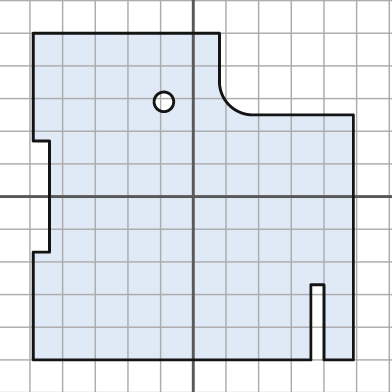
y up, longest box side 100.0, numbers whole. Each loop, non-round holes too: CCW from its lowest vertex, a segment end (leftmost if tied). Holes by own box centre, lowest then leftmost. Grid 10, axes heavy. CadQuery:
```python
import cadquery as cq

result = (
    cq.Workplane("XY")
    .moveTo(-49.0, -50.0)
    .lineTo(36.0, -50.0)
    .lineTo(36.0, -27.0)
    .lineTo(40.0, -27.0)
    .lineTo(40.0, -50.0)
    .lineTo(49.0, -50.0)
    .lineTo(49.0, 25.0)
    .lineTo(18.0, 25.0)
    .threePointArc((11.0, 28.0), (8.0, 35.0))
    .lineTo(8.0, 50.0)
    .lineTo(-49.0, 50.0)
    .lineTo(-49.0, 17.0)
    .lineTo(-44.0, 17.0)
    .lineTo(-44.0, -17.0)
    .lineTo(-49.0, -17.0)
    .close()
    .moveTo(-9.0, 29.0)
    .circle(3.0)
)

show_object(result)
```